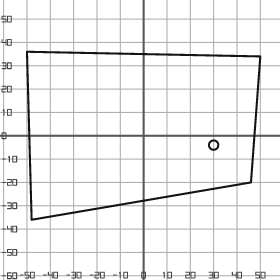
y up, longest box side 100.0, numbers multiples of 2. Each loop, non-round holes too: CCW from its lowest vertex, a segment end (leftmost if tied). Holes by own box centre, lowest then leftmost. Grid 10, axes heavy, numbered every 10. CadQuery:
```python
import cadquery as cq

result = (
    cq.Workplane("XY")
    .moveTo(-48.0, -36.0)
    .lineTo(46.0, -20.0)
    .lineTo(50.0, 34.0)
    .lineTo(-50.0, 36.0)
    .close()
    .moveTo(30.0, -4.0)
    .circle(2.0)
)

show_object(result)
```